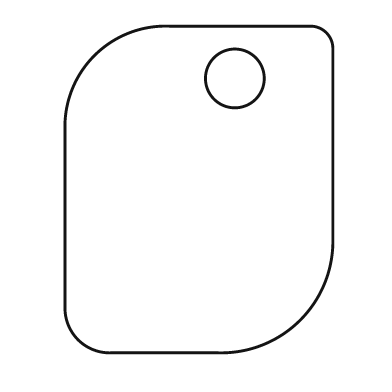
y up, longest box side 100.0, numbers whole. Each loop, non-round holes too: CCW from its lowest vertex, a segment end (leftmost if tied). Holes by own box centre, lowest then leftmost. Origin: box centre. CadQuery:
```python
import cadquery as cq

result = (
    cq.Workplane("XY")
    .moveTo(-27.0, -50.0)
    .lineTo(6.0, -50.0)
    .threePointArc((31.0, -40.0), (41.0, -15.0))
    .lineTo(41.0, 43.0)
    .threePointArc((39.0, 48.0), (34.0, 50.0))
    .lineTo(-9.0, 50.0)
    .threePointArc((-32.0, 41.0), (-41.0, 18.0))
    .lineTo(-41.0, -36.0)
    .threePointArc((-37.0, -46.0), (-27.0, -50.0))
    .close()
    .moveTo(11.0, 34.0)
    .circle(9.0)
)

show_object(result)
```